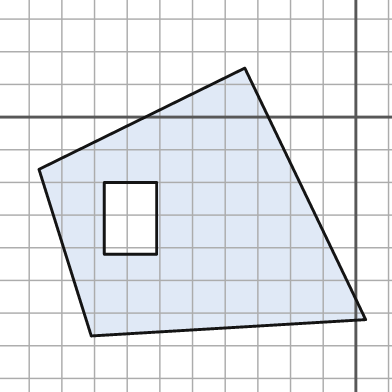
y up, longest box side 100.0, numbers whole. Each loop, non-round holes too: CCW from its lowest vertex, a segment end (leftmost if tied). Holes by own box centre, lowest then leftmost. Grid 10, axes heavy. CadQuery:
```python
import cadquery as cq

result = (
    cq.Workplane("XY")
    .moveTo(-81.0, -67.0)
    .lineTo(3.0, -62.0)
    .lineTo(-34.0, 15.0)
    .lineTo(-97.0, -16.0)
    .close()
    .moveTo(-77.0, -42.0)
    .lineTo(-61.0, -42.0)
    .lineTo(-61.0, -20.0)
    .lineTo(-77.0, -20.0)
    .close()
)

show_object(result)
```